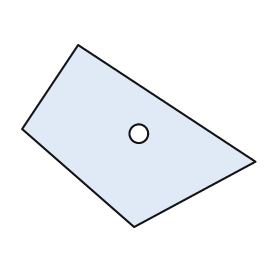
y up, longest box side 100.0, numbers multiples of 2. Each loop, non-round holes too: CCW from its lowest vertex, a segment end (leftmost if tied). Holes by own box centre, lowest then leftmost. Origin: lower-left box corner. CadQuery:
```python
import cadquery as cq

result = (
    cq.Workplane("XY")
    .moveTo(48.0, 0.0)
    .lineTo(100.0, 28.0)
    .lineTo(24.0, 78.0)
    .lineTo(0.0, 42.0)
    .close()
    .moveTo(50.0, 40.0)
    .circle(4.0)
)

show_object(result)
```